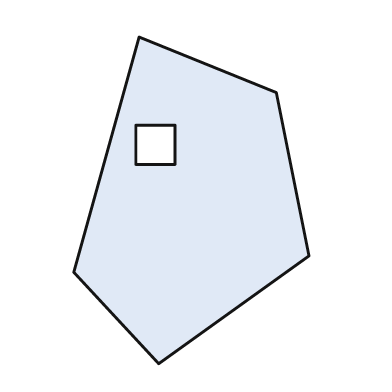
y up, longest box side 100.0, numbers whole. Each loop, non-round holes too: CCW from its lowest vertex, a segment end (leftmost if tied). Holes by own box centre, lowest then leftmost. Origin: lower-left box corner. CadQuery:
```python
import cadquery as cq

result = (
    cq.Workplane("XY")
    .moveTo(26.0, 0.0)
    .lineTo(72.0, 33.0)
    .lineTo(62.0, 83.0)
    .lineTo(20.0, 100.0)
    .lineTo(0.0, 28.0)
    .close()
    .moveTo(19.0, 61.0)
    .lineTo(31.0, 61.0)
    .lineTo(31.0, 73.0)
    .lineTo(19.0, 73.0)
    .close()
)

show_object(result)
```